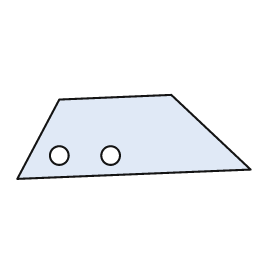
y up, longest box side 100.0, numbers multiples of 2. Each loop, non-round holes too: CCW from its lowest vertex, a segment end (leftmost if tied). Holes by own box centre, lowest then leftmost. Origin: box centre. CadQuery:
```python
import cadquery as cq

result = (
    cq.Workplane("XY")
    .moveTo(-50.0, -18.0)
    .lineTo(50.0, -14.0)
    .lineTo(16.0, 18.0)
    .lineTo(-32.0, 16.0)
    .close()
    .moveTo(-32.0, -8.0)
    .circle(4.0)
    .moveTo(-10.0, -8.0)
    .circle(4.0)
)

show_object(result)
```